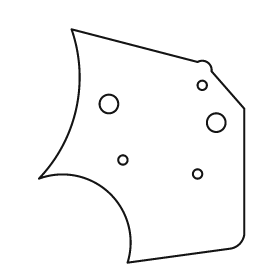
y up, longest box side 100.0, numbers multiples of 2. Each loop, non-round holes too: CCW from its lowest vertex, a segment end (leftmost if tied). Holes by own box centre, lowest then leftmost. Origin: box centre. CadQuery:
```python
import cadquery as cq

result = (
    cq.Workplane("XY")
    .moveTo(-6.0, -50.0)
    .lineTo(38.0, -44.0)
    .threePointArc((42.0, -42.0), (44.0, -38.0))
    .lineTo(44.0, 16.0)
    .lineTo(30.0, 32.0)
    .threePointArc((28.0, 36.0), (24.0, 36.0))
    .lineTo(-30.0, 50.0)
    .threePointArc((-28.0, 16.0), (-44.0, -14.0))
    .threePointArc((-14.0, -20.0), (-6.0, -50.0))
    .close()
    .moveTo(24.0, -12.0)
    .circle(2.0)
    .moveTo(-8.0, -6.0)
    .circle(2.0)
    .moveTo(32.0, 10.0)
    .circle(4.0)
    .moveTo(-14.0, 18.0)
    .circle(4.0)
    .moveTo(26.0, 26.0)
    .circle(2.0)
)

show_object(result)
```